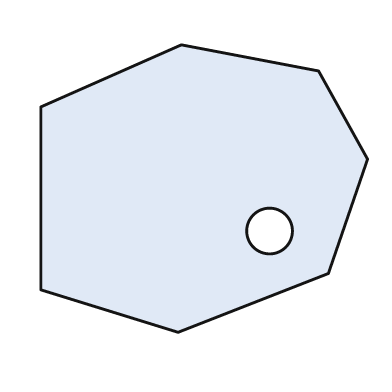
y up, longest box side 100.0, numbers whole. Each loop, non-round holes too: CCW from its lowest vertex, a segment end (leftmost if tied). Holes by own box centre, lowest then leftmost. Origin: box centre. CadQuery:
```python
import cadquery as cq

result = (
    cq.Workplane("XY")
    .moveTo(-8.0, -44.0)
    .lineTo(38.0, -26.0)
    .lineTo(50.0, 9.0)
    .lineTo(35.0, 36.0)
    .lineTo(-7.0, 44.0)
    .lineTo(-50.0, 25.0)
    .lineTo(-50.0, -31.0)
    .close()
    .moveTo(20.0, -13.0)
    .circle(7.0)
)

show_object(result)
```